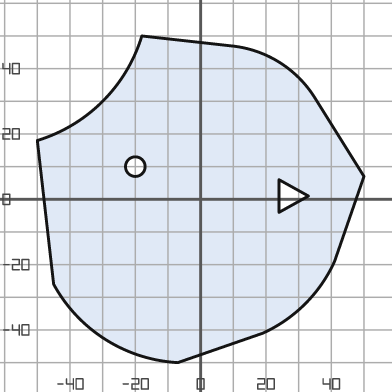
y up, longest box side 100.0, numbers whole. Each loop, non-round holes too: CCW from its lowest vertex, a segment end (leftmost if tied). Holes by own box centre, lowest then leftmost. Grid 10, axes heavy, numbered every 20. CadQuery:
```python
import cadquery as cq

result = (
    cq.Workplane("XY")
    .moveTo(-7.0, -50.0)
    .lineTo(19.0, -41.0)
    .threePointArc((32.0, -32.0), (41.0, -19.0))
    .lineTo(50.0, 7.0)
    .lineTo(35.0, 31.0)
    .threePointArc((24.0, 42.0), (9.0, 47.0))
    .lineTo(-18.0, 50.0)
    .threePointArc((-30.0, 30.0), (-50.0, 18.0))
    .lineTo(-45.0, -26.0)
    .threePointArc((-29.0, -43.0), (-7.0, -50.0))
    .close()
    .moveTo(24.0, -4.0)
    .lineTo(33.0, 1.0)
    .lineTo(24.0, 6.0)
    .close()
    .moveTo(-20.0, 10.0)
    .circle(3.0)
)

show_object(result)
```